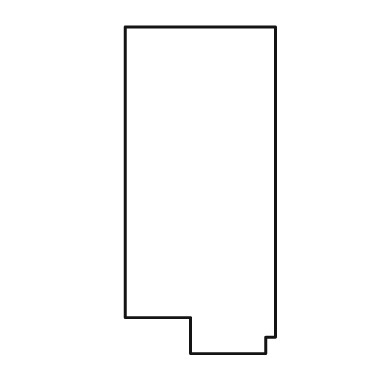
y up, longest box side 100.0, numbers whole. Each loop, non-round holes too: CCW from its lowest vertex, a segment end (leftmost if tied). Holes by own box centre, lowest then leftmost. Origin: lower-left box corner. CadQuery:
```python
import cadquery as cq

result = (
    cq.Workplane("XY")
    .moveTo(20.0, 0.0)
    .lineTo(43.0, 0.0)
    .lineTo(43.0, 5.0)
    .lineTo(46.0, 5.0)
    .lineTo(46.0, 100.0)
    .lineTo(0.0, 100.0)
    .lineTo(0.0, 11.0)
    .lineTo(20.0, 11.0)
    .close()
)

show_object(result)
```